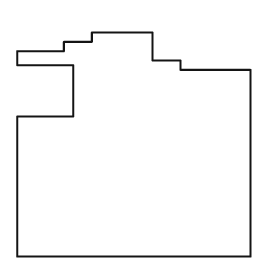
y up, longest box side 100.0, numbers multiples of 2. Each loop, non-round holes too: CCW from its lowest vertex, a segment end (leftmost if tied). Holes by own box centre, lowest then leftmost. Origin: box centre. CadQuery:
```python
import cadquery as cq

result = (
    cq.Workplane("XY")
    .moveTo(-50.0, -48.0)
    .lineTo(50.0, -48.0)
    .lineTo(50.0, 32.0)
    .lineTo(20.0, 32.0)
    .lineTo(20.0, 36.0)
    .lineTo(8.0, 36.0)
    .lineTo(8.0, 48.0)
    .lineTo(-18.0, 48.0)
    .lineTo(-18.0, 44.0)
    .lineTo(-30.0, 44.0)
    .lineTo(-30.0, 40.0)
    .lineTo(-50.0, 40.0)
    .lineTo(-50.0, 34.0)
    .lineTo(-26.0, 34.0)
    .lineTo(-26.0, 12.0)
    .lineTo(-50.0, 12.0)
    .close()
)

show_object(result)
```